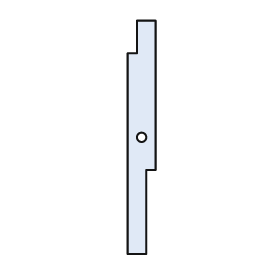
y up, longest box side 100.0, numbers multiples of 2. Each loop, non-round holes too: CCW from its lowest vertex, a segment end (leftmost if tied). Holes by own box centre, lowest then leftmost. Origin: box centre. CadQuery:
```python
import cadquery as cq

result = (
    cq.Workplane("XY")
    .moveTo(-6.0, -50.0)
    .lineTo(2.0, -50.0)
    .lineTo(2.0, -14.0)
    .lineTo(6.0, -14.0)
    .lineTo(6.0, 50.0)
    .lineTo(-2.0, 50.0)
    .lineTo(-2.0, 36.0)
    .lineTo(-6.0, 36.0)
    .close()
    .moveTo(0.0, 0.0)
    .circle(2.0)
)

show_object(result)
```